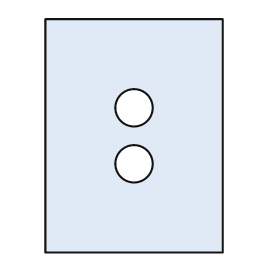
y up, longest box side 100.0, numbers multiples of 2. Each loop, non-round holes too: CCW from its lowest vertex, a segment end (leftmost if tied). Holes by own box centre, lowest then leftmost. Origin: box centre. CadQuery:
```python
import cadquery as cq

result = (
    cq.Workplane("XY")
    .moveTo(-38.0, -50.0)
    .lineTo(38.0, -50.0)
    .lineTo(38.0, 50.0)
    .lineTo(-38.0, 50.0)
    .close()
    .moveTo(0.0, -12.0)
    .circle(8.0)
    .moveTo(0.0, 12.0)
    .circle(8.0)
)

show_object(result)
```